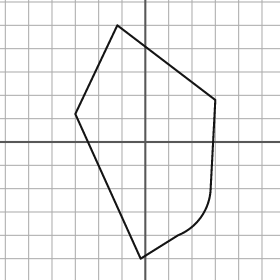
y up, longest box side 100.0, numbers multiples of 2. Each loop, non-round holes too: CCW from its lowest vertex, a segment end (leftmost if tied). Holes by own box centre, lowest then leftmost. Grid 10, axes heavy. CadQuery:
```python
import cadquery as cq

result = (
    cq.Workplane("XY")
    .moveTo(-2.0, -50.0)
    .lineTo(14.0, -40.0)
    .threePointArc((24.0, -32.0), (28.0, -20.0))
    .lineTo(30.0, 18.0)
    .lineTo(-12.0, 50.0)
    .lineTo(-30.0, 12.0)
    .close()
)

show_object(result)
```